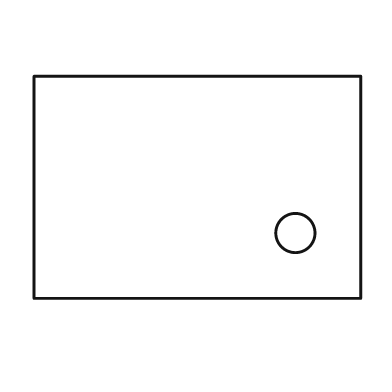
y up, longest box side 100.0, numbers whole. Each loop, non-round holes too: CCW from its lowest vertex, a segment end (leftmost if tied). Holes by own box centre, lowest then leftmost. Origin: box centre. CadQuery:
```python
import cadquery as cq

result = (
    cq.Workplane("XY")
    .moveTo(-50.0, -34.0)
    .lineTo(50.0, -34.0)
    .lineTo(50.0, 34.0)
    .lineTo(-50.0, 34.0)
    .close()
    .moveTo(30.0, -14.0)
    .circle(6.0)
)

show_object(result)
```